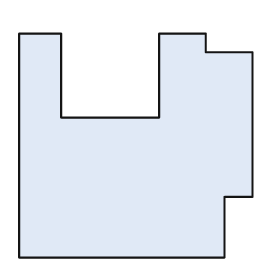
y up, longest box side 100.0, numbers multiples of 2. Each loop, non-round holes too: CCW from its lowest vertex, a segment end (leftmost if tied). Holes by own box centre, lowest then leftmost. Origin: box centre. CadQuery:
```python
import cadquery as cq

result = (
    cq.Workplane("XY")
    .moveTo(-50.0, -48.0)
    .lineTo(38.0, -48.0)
    .lineTo(38.0, -22.0)
    .lineTo(50.0, -22.0)
    .lineTo(50.0, 40.0)
    .lineTo(30.0, 40.0)
    .lineTo(30.0, 48.0)
    .lineTo(10.0, 48.0)
    .lineTo(10.0, 12.0)
    .lineTo(-32.0, 12.0)
    .lineTo(-32.0, 48.0)
    .lineTo(-50.0, 48.0)
    .close()
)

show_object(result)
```